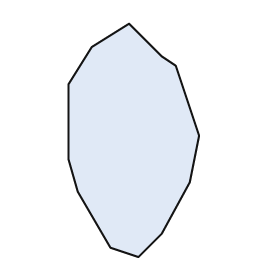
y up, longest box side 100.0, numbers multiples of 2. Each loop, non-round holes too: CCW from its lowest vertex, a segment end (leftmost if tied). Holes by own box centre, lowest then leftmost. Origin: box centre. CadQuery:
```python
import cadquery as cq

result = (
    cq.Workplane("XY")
    .moveTo(2.0, -50.0)
    .lineTo(12.0, -40.0)
    .lineTo(24.0, -18.0)
    .lineTo(28.0, 2.0)
    .lineTo(18.0, 32.0)
    .lineTo(12.0, 36.0)
    .lineTo(-2.0, 50.0)
    .lineTo(-18.0, 40.0)
    .lineTo(-28.0, 24.0)
    .lineTo(-28.0, -8.0)
    .lineTo(-24.0, -22.0)
    .lineTo(-10.0, -46.0)
    .close()
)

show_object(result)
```